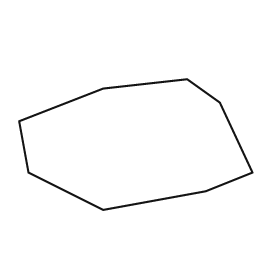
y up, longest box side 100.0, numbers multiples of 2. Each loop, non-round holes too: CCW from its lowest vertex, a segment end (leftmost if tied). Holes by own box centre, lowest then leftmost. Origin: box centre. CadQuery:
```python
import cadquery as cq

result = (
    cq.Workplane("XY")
    .moveTo(-14.0, -28.0)
    .lineTo(30.0, -20.0)
    .lineTo(50.0, -12.0)
    .lineTo(36.0, 18.0)
    .lineTo(22.0, 28.0)
    .lineTo(-14.0, 24.0)
    .lineTo(-50.0, 10.0)
    .lineTo(-46.0, -12.0)
    .close()
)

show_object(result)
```